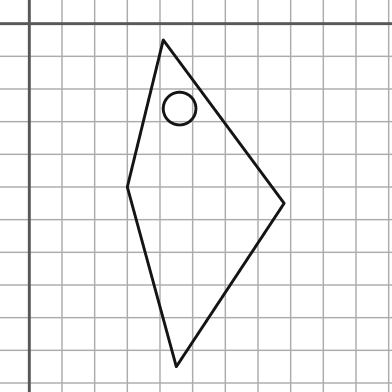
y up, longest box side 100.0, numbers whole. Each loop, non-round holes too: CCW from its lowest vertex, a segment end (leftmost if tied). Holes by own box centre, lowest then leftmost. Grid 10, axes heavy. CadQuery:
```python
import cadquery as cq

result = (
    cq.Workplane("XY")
    .moveTo(45.0, -105.0)
    .lineTo(78.0, -55.0)
    .lineTo(41.0, -5.0)
    .lineTo(30.0, -50.0)
    .close()
    .moveTo(46.0, -26.0)
    .circle(5.0)
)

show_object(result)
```